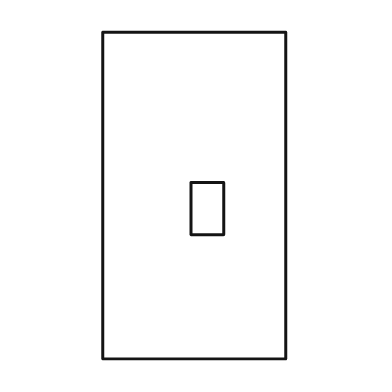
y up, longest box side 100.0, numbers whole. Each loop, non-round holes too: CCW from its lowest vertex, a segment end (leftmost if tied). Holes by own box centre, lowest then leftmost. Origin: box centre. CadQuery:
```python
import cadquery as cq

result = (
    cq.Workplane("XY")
    .moveTo(-28.0, -50.0)
    .lineTo(28.0, -50.0)
    .lineTo(28.0, 50.0)
    .lineTo(-28.0, 50.0)
    .close()
    .moveTo(-1.0, -12.0)
    .lineTo(9.0, -12.0)
    .lineTo(9.0, 4.0)
    .lineTo(-1.0, 4.0)
    .close()
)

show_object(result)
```